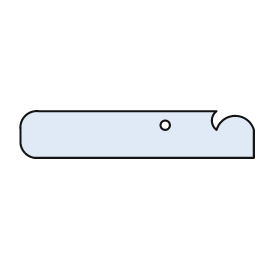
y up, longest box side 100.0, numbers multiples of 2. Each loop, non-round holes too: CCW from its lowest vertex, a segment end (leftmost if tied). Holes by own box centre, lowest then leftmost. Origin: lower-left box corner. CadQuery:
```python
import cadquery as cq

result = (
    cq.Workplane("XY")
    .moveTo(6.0, 0.0)
    .lineTo(100.0, 0.0)
    .lineTo(100.0, 12.0)
    .threePointArc((92.0, 18.0), (84.0, 12.0))
    .threePointArc((82.0, 16.0), (84.0, 20.0))
    .lineTo(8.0, 20.0)
    .threePointArc((2.0, 18.0), (0.0, 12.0))
    .lineTo(0.0, 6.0)
    .threePointArc((2.0, 2.0), (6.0, 0.0))
    .close()
    .moveTo(62.0, 14.0)
    .circle(2.0)
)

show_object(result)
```